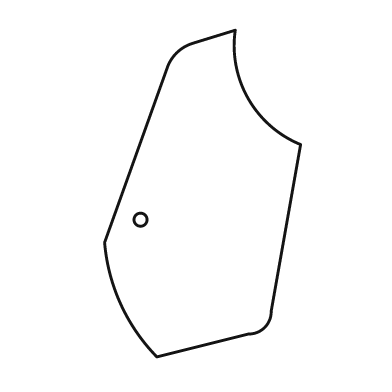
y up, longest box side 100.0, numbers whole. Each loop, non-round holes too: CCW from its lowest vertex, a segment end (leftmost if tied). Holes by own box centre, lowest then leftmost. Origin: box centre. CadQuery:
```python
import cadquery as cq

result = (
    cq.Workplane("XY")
    .moveTo(-14.0, -50.0)
    .lineTo(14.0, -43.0)
    .threePointArc((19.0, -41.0), (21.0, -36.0))
    .lineTo(30.0, 15.0)
    .threePointArc((14.0, 29.0), (10.0, 50.0))
    .lineTo(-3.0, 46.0)
    .threePointArc((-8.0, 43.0), (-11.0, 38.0))
    .lineTo(-30.0, -15.0)
    .threePointArc((-25.0, -34.0), (-14.0, -50.0))
    .close()
    .moveTo(-19.0, -8.0)
    .circle(2.0)
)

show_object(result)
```